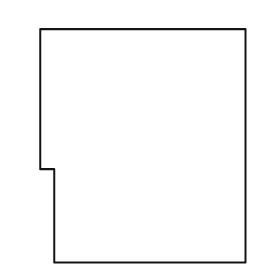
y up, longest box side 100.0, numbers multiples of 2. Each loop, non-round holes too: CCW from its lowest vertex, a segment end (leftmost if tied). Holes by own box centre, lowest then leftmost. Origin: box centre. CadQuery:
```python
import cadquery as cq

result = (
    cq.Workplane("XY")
    .moveTo(-38.0, -50.0)
    .lineTo(44.0, -50.0)
    .lineTo(44.0, 50.0)
    .lineTo(-44.0, 50.0)
    .lineTo(-44.0, -10.0)
    .lineTo(-38.0, -10.0)
    .close()
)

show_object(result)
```